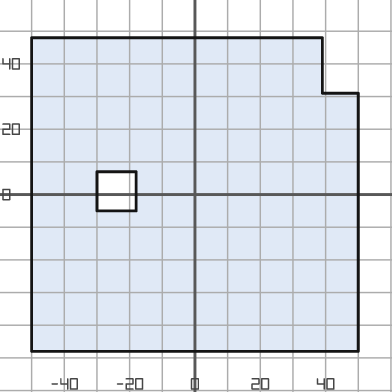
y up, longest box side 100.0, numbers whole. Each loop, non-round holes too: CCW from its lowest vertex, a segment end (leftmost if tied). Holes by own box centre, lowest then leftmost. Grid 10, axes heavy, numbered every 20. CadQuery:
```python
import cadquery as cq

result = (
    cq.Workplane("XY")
    .moveTo(-50.0, -48.0)
    .lineTo(50.0, -48.0)
    .lineTo(50.0, 31.0)
    .lineTo(39.0, 31.0)
    .lineTo(39.0, 48.0)
    .lineTo(-50.0, 48.0)
    .close()
    .moveTo(-30.0, -5.0)
    .lineTo(-18.0, -5.0)
    .lineTo(-18.0, 7.0)
    .lineTo(-30.0, 7.0)
    .close()
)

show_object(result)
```